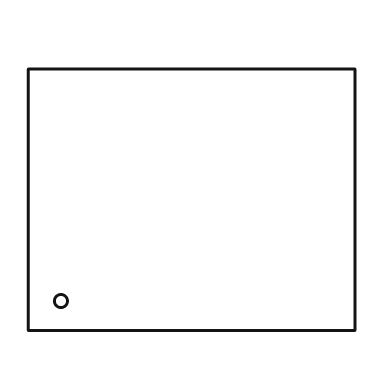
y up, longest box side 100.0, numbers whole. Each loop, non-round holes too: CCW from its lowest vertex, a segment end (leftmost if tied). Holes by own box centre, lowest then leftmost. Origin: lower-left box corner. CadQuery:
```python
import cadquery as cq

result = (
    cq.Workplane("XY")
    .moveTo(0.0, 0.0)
    .lineTo(100.0, 0.0)
    .lineTo(100.0, 80.0)
    .lineTo(0.0, 80.0)
    .close()
    .moveTo(10.0, 9.0)
    .circle(2.0)
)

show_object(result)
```